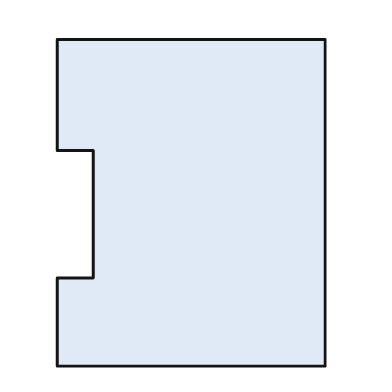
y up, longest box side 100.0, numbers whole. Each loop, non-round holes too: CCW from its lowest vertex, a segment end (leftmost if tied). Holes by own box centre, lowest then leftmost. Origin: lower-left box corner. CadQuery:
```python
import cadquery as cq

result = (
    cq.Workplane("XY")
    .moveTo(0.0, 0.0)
    .lineTo(82.0, 0.0)
    .lineTo(82.0, 100.0)
    .lineTo(0.0, 100.0)
    .lineTo(0.0, 66.0)
    .lineTo(11.0, 66.0)
    .lineTo(11.0, 27.0)
    .lineTo(0.0, 27.0)
    .close()
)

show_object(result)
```